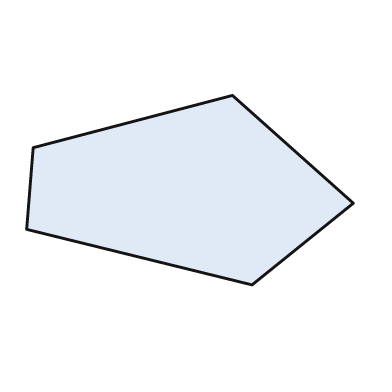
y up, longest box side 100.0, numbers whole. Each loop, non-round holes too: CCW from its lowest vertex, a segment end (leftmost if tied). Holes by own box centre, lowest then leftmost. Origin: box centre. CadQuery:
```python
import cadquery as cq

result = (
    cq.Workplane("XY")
    .moveTo(19.0, -29.0)
    .lineTo(50.0, -4.0)
    .lineTo(13.0, 29.0)
    .lineTo(-48.0, 13.0)
    .lineTo(-50.0, -12.0)
    .close()
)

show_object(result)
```